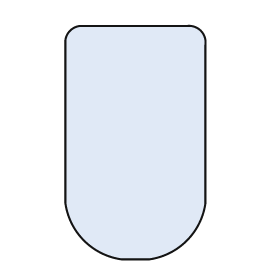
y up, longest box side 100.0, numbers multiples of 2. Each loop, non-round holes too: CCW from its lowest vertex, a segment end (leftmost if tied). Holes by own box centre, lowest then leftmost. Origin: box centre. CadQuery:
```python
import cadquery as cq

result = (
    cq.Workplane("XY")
    .moveTo(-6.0, -50.0)
    .lineTo(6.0, -50.0)
    .threePointArc((22.0, -42.0), (30.0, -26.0))
    .lineTo(30.0, 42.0)
    .threePointArc((28.0, 48.0), (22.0, 50.0))
    .lineTo(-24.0, 50.0)
    .threePointArc((-28.0, 48.0), (-30.0, 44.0))
    .lineTo(-30.0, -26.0)
    .threePointArc((-22.0, -42.0), (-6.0, -50.0))
    .close()
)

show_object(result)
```